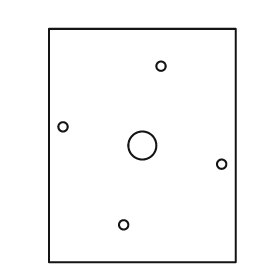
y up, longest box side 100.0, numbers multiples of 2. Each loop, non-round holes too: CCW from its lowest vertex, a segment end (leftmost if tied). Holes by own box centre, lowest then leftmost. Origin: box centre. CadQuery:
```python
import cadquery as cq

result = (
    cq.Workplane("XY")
    .moveTo(-40.0, -50.0)
    .lineTo(40.0, -50.0)
    .lineTo(40.0, 50.0)
    .lineTo(-40.0, 50.0)
    .close()
    .moveTo(-8.0, -34.0)
    .circle(2.0)
    .moveTo(34.0, -8.0)
    .circle(2.0)
    .moveTo(0.0, 0.0)
    .circle(6.0)
    .moveTo(-34.0, 8.0)
    .circle(2.0)
    .moveTo(8.0, 34.0)
    .circle(2.0)
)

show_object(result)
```